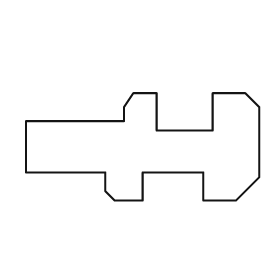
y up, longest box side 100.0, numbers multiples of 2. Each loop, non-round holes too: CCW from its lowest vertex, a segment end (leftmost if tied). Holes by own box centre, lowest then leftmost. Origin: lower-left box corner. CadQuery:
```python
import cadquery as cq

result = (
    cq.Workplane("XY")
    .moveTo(38.0, 0.0)
    .lineTo(50.0, 0.0)
    .lineTo(50.0, 12.0)
    .lineTo(76.0, 12.0)
    .lineTo(76.0, 0.0)
    .lineTo(90.0, 0.0)
    .lineTo(100.0, 10.0)
    .lineTo(100.0, 40.0)
    .lineTo(94.0, 46.0)
    .lineTo(80.0, 46.0)
    .lineTo(80.0, 30.0)
    .lineTo(56.0, 30.0)
    .lineTo(56.0, 46.0)
    .lineTo(46.0, 46.0)
    .lineTo(42.0, 40.0)
    .lineTo(42.0, 34.0)
    .lineTo(0.0, 34.0)
    .lineTo(0.0, 12.0)
    .lineTo(34.0, 12.0)
    .lineTo(34.0, 4.0)
    .close()
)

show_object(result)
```